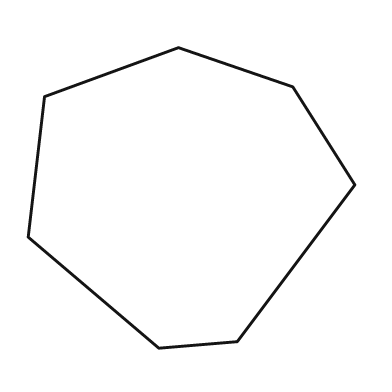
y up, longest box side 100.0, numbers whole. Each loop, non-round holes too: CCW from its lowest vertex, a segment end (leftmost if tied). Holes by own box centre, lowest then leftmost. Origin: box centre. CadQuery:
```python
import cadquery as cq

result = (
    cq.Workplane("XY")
    .moveTo(-10.0, -46.0)
    .lineTo(14.0, -44.0)
    .lineTo(50.0, 4.0)
    .lineTo(31.0, 34.0)
    .lineTo(-4.0, 46.0)
    .lineTo(-45.0, 31.0)
    .lineTo(-50.0, -12.0)
    .close()
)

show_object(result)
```